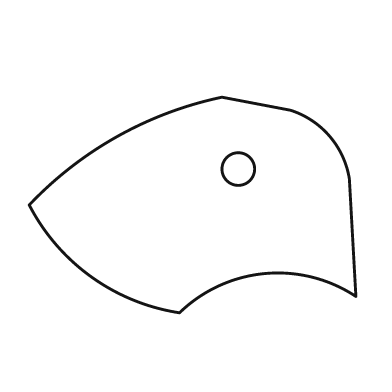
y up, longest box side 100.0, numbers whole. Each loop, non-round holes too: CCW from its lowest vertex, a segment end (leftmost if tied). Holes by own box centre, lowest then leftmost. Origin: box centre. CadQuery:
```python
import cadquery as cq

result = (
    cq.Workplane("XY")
    .moveTo(-4.0, -33.0)
    .threePointArc((22.0, -21.0), (50.0, -28.0))
    .lineTo(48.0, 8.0)
    .threePointArc((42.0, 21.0), (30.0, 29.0))
    .lineTo(9.0, 33.0)
    .threePointArc((-23.0, 21.0), (-50.0, 0.0))
    .threePointArc((-31.0, -22.0), (-4.0, -33.0))
    .close()
    .moveTo(14.0, 11.0)
    .circle(5.0)
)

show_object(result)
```